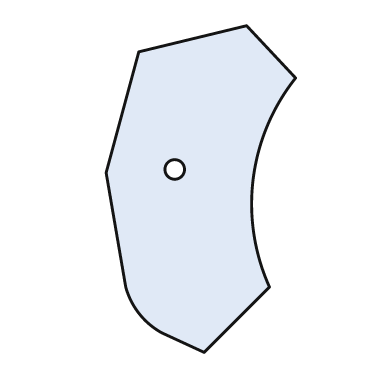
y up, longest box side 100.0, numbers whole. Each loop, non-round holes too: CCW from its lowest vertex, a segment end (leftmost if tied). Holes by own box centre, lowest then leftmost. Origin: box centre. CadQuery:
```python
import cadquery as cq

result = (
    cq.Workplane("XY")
    .moveTo(1.0, -50.0)
    .lineTo(21.0, -30.0)
    .threePointArc((16.0, 3.0), (29.0, 34.0))
    .lineTo(14.0, 50.0)
    .lineTo(-19.0, 42.0)
    .lineTo(-29.0, 5.0)
    .lineTo(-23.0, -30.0)
    .threePointArc((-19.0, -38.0), (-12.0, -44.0))
    .close()
    .moveTo(-8.0, 6.0)
    .circle(3.0)
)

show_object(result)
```